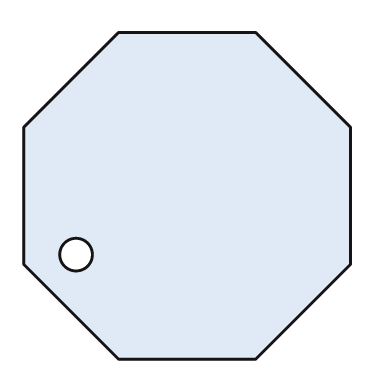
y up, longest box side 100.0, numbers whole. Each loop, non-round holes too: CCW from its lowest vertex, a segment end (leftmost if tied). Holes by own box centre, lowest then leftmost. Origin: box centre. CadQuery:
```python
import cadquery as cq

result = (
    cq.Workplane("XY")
    .moveTo(-21.0, -50.0)
    .lineTo(21.0, -50.0)
    .lineTo(50.0, -21.0)
    .lineTo(50.0, 21.0)
    .lineTo(21.0, 50.0)
    .lineTo(-21.0, 50.0)
    .lineTo(-50.0, 21.0)
    .lineTo(-50.0, -21.0)
    .close()
    .moveTo(-34.0, -18.0)
    .circle(5.0)
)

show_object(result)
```